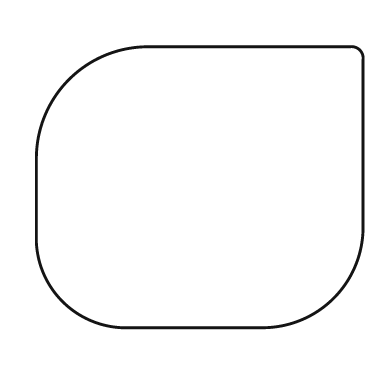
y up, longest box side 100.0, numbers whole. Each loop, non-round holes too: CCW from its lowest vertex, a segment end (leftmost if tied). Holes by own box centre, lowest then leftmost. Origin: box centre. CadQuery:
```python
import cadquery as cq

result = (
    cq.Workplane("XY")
    .moveTo(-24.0, -43.0)
    .lineTo(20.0, -43.0)
    .threePointArc((41.0, -34.0), (50.0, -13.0))
    .lineTo(50.0, 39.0)
    .threePointArc((49.0, 42.0), (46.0, 43.0))
    .lineTo(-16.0, 43.0)
    .threePointArc((-40.0, 33.0), (-50.0, 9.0))
    .lineTo(-50.0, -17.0)
    .threePointArc((-42.0, -35.0), (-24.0, -43.0))
    .close()
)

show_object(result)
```